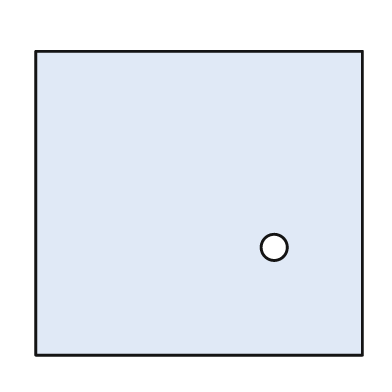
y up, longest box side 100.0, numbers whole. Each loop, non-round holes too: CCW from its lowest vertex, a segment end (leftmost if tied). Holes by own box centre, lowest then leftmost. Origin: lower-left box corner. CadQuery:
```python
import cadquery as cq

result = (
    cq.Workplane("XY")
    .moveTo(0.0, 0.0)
    .lineTo(100.0, 0.0)
    .lineTo(100.0, 93.0)
    .lineTo(0.0, 93.0)
    .close()
    .moveTo(73.0, 33.0)
    .circle(4.0)
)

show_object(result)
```